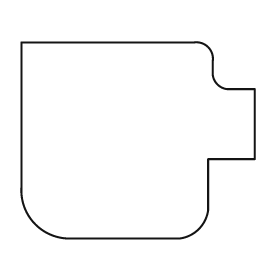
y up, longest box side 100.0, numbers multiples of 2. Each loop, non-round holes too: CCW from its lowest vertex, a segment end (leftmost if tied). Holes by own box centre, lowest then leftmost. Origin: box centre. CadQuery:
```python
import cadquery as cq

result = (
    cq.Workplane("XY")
    .moveTo(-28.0, -42.0)
    .lineTo(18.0, -42.0)
    .threePointArc((26.0, -38.0), (30.0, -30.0))
    .lineTo(30.0, -8.0)
    .lineTo(50.0, -8.0)
    .lineTo(50.0, 22.0)
    .lineTo(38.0, 22.0)
    .threePointArc((34.0, 24.0), (32.0, 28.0))
    .lineTo(32.0, 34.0)
    .threePointArc((30.0, 40.0), (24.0, 42.0))
    .lineTo(-50.0, 42.0)
    .lineTo(-50.0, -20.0)
    .threePointArc((-44.0, -36.0), (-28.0, -42.0))
    .close()
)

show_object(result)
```